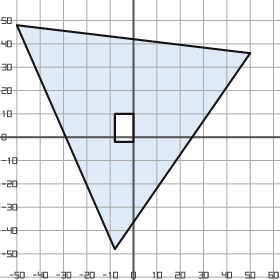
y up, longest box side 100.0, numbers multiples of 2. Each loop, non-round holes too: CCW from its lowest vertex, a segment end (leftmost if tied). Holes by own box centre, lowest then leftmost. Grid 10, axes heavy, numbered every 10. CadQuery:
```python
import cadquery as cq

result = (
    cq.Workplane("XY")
    .moveTo(-8.0, -48.0)
    .lineTo(50.0, 36.0)
    .lineTo(-50.0, 48.0)
    .close()
    .moveTo(-8.0, -2.0)
    .lineTo(0.0, -2.0)
    .lineTo(0.0, 10.0)
    .lineTo(-8.0, 10.0)
    .close()
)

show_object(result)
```